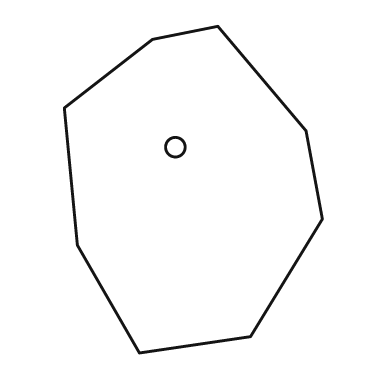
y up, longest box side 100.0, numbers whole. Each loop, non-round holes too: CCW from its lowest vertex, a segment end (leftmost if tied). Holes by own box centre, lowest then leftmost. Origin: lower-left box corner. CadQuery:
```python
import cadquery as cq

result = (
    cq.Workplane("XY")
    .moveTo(23.0, 0.0)
    .lineTo(57.0, 5.0)
    .lineTo(79.0, 41.0)
    .lineTo(74.0, 68.0)
    .lineTo(47.0, 100.0)
    .lineTo(27.0, 96.0)
    .lineTo(0.0, 75.0)
    .lineTo(4.0, 33.0)
    .close()
    .moveTo(34.0, 63.0)
    .circle(3.0)
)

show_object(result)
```